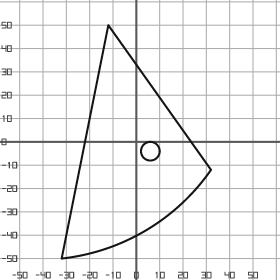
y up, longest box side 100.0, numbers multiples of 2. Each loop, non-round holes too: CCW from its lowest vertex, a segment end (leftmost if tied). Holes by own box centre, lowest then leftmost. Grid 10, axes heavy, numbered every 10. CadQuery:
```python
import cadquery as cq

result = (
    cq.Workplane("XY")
    .moveTo(-32.0, -50.0)
    .threePointArc((4.0, -38.0), (32.0, -12.0))
    .lineTo(-12.0, 50.0)
    .close()
    .moveTo(6.0, -4.0)
    .circle(4.0)
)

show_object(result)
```